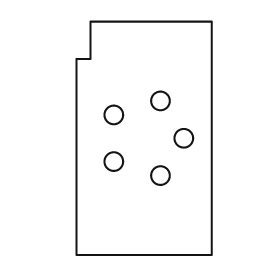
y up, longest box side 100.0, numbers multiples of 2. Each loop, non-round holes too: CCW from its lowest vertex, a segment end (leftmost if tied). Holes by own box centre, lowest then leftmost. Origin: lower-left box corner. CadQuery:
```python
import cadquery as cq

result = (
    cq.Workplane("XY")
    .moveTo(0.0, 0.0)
    .lineTo(58.0, 0.0)
    .lineTo(58.0, 100.0)
    .lineTo(6.0, 100.0)
    .lineTo(6.0, 84.0)
    .lineTo(0.0, 84.0)
    .close()
    .moveTo(36.0, 34.0)
    .circle(4.0)
    .moveTo(16.0, 40.0)
    .circle(4.0)
    .moveTo(46.0, 50.0)
    .circle(4.0)
    .moveTo(16.0, 60.0)
    .circle(4.0)
    .moveTo(36.0, 66.0)
    .circle(4.0)
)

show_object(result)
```